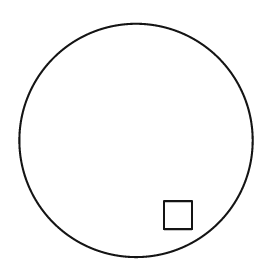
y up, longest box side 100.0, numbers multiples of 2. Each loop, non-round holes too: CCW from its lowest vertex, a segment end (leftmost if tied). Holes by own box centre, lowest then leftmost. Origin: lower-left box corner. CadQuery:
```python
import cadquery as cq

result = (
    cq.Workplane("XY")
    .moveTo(50.0, 50.0)
    .circle(50.0)
    .moveTo(62.0, 12.0)
    .lineTo(74.0, 12.0)
    .lineTo(74.0, 24.0)
    .lineTo(62.0, 24.0)
    .close()
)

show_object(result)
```